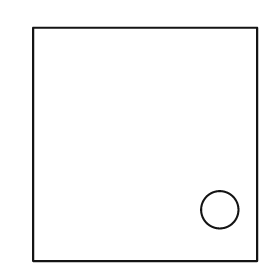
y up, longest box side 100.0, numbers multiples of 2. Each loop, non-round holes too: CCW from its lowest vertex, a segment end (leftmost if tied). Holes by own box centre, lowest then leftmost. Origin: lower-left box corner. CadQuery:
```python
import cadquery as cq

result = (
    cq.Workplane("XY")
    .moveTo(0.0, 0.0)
    .lineTo(96.0, 0.0)
    .lineTo(96.0, 100.0)
    .lineTo(0.0, 100.0)
    .close()
    .moveTo(80.0, 22.0)
    .circle(8.0)
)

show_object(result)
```